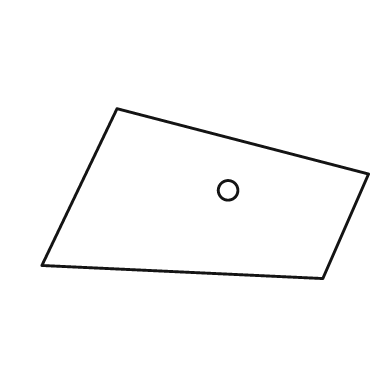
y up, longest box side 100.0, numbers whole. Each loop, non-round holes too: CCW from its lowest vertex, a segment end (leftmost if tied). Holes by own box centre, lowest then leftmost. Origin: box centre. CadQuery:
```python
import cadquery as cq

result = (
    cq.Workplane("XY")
    .moveTo(36.0, -26.0)
    .lineTo(50.0, 6.0)
    .lineTo(-27.0, 26.0)
    .lineTo(-50.0, -22.0)
    .close()
    .moveTo(7.0, 1.0)
    .circle(3.0)
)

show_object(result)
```